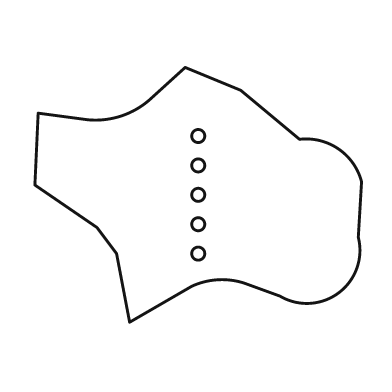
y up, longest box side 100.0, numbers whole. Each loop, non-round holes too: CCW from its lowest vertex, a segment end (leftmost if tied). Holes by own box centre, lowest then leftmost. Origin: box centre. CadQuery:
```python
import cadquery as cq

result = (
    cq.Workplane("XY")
    .moveTo(-21.0, -39.0)
    .lineTo(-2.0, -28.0)
    .threePointArc((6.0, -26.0), (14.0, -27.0))
    .lineTo(25.0, -31.0)
    .threePointArc((43.0, -30.0), (49.0, -13.0))
    .lineTo(50.0, 4.0)
    .threePointArc((43.0, 14.0), (31.0, 17.0))
    .lineTo(13.0, 32.0)
    .lineTo(-4.0, 39.0)
    .lineTo(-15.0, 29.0)
    .threePointArc((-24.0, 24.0), (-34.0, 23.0))
    .lineTo(-49.0, 25.0)
    .lineTo(-50.0, 3.0)
    .lineTo(-31.0, -10.0)
    .lineTo(-25.0, -18.0)
    .close()
    .moveTo(0.0, -18.0)
    .circle(2.0)
    .moveTo(0.0, -9.0)
    .circle(2.0)
    .moveTo(0.0, 0.0)
    .circle(2.0)
    .moveTo(0.0, 9.0)
    .circle(2.0)
    .moveTo(0.0, 18.0)
    .circle(2.0)
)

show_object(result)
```